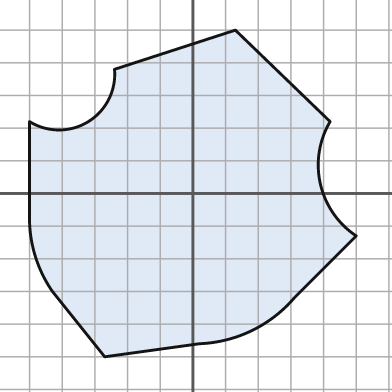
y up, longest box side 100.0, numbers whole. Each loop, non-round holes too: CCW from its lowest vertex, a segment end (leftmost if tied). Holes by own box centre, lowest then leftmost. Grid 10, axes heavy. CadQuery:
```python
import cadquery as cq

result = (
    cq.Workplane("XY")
    .moveTo(-27.0, -50.0)
    .lineTo(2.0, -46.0)
    .threePointArc((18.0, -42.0), (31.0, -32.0))
    .lineTo(50.0, -13.0)
    .threePointArc((39.0, 3.0), (42.0, 22.0))
    .lineTo(13.0, 50.0)
    .lineTo(-24.0, 38.0)
    .threePointArc((-32.0, 22.0), (-50.0, 22.0))
    .lineTo(-50.0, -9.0)
    .threePointArc((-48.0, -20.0), (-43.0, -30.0))
    .close()
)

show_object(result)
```